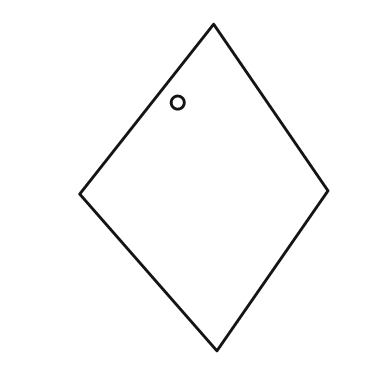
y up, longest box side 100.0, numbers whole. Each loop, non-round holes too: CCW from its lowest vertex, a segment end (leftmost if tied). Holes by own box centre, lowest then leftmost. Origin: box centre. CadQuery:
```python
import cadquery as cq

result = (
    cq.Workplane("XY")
    .moveTo(4.0, -50.0)
    .lineTo(38.0, -1.0)
    .lineTo(3.0, 50.0)
    .lineTo(-38.0, -2.0)
    .close()
    .moveTo(-8.0, 26.0)
    .circle(2.0)
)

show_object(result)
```